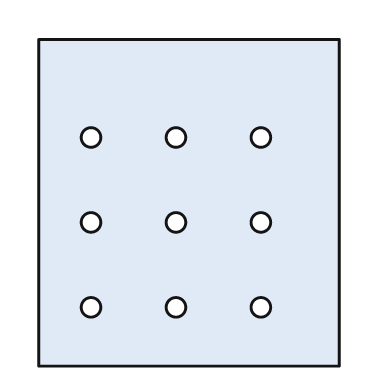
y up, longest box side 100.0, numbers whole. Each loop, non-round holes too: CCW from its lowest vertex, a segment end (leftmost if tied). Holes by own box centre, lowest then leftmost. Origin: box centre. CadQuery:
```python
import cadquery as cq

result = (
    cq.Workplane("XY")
    .moveTo(-46.0, -50.0)
    .lineTo(46.0, -50.0)
    .lineTo(46.0, 50.0)
    .lineTo(-46.0, 50.0)
    .close()
    .moveTo(-30.0, -32.0)
    .circle(3.0)
    .moveTo(-4.0, -32.0)
    .circle(3.0)
    .moveTo(22.0, -32.0)
    .circle(3.0)
    .moveTo(-30.0, -6.0)
    .circle(3.0)
    .moveTo(-4.0, -6.0)
    .circle(3.0)
    .moveTo(22.0, -6.0)
    .circle(3.0)
    .moveTo(-30.0, 20.0)
    .circle(3.0)
    .moveTo(-4.0, 20.0)
    .circle(3.0)
    .moveTo(22.0, 20.0)
    .circle(3.0)
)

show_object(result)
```